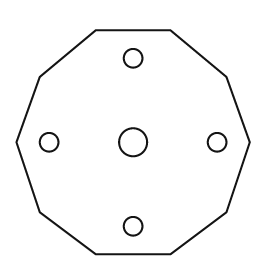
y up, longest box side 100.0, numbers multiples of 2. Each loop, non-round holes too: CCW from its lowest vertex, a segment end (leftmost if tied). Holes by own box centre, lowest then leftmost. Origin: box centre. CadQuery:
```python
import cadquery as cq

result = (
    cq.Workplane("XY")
    .moveTo(-16.0, -48.0)
    .lineTo(16.0, -48.0)
    .lineTo(40.0, -30.0)
    .lineTo(50.0, 0.0)
    .lineTo(40.0, 28.0)
    .lineTo(16.0, 48.0)
    .lineTo(-16.0, 48.0)
    .lineTo(-40.0, 28.0)
    .lineTo(-50.0, 0.0)
    .lineTo(-40.0, -30.0)
    .close()
    .moveTo(0.0, -36.0)
    .circle(4.0)
    .moveTo(-36.0, 0.0)
    .circle(4.0)
    .moveTo(0.0, 0.0)
    .circle(6.0)
    .moveTo(36.0, 0.0)
    .circle(4.0)
    .moveTo(0.0, 36.0)
    .circle(4.0)
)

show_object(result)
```